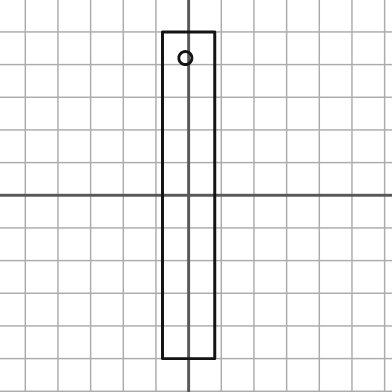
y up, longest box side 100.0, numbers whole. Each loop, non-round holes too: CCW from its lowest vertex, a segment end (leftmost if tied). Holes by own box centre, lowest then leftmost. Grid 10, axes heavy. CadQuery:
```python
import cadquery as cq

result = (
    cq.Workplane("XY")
    .moveTo(-8.0, -50.0)
    .lineTo(8.0, -50.0)
    .lineTo(8.0, 50.0)
    .lineTo(-8.0, 50.0)
    .close()
    .moveTo(-1.0, 42.0)
    .circle(2.0)
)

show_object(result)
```